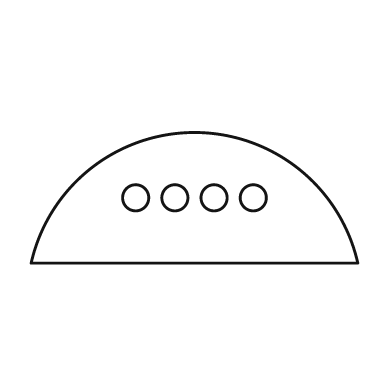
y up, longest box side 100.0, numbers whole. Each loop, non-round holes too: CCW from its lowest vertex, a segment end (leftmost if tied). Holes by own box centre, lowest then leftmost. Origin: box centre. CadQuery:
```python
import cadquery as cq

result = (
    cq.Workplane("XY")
    .moveTo(-50.0, -20.0)
    .lineTo(50.0, -20.0)
    .threePointArc((0.0, 20.0), (-50.0, -20.0))
    .close()
    .moveTo(-18.0, 0.0)
    .circle(4.0)
    .moveTo(-6.0, 0.0)
    .circle(4.0)
    .moveTo(6.0, 0.0)
    .circle(4.0)
    .moveTo(18.0, 0.0)
    .circle(4.0)
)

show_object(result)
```